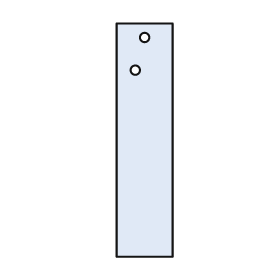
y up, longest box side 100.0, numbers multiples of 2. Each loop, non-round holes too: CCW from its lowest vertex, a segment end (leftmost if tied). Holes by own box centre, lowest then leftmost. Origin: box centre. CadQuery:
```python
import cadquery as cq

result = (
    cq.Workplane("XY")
    .moveTo(-12.0, -50.0)
    .lineTo(12.0, -50.0)
    .lineTo(12.0, 50.0)
    .lineTo(-12.0, 50.0)
    .close()
    .moveTo(-4.0, 30.0)
    .circle(2.0)
    .moveTo(0.0, 44.0)
    .circle(2.0)
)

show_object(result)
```